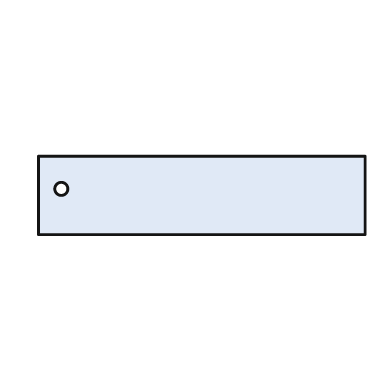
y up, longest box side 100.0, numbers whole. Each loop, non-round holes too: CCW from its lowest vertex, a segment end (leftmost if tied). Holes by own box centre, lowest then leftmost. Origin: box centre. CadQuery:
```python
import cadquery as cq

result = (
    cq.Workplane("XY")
    .moveTo(-50.0, -12.0)
    .lineTo(50.0, -12.0)
    .lineTo(50.0, 12.0)
    .lineTo(-50.0, 12.0)
    .close()
    .moveTo(-43.0, 2.0)
    .circle(2.0)
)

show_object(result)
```